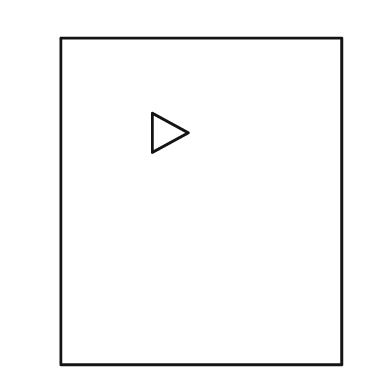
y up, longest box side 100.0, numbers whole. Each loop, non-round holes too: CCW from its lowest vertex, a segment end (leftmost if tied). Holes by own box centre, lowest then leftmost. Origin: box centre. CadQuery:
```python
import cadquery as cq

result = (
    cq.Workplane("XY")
    .moveTo(-43.0, -50.0)
    .lineTo(43.0, -50.0)
    .lineTo(43.0, 50.0)
    .lineTo(-43.0, 50.0)
    .close()
    .moveTo(-15.0, 15.0)
    .lineTo(-4.0, 21.0)
    .lineTo(-15.0, 27.0)
    .close()
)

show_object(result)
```